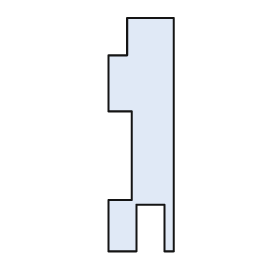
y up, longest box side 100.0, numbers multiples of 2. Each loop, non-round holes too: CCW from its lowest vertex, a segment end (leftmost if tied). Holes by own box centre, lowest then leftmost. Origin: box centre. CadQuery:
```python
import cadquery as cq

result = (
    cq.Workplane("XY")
    .moveTo(-14.0, -50.0)
    .lineTo(-2.0, -50.0)
    .lineTo(-2.0, -30.0)
    .lineTo(10.0, -30.0)
    .lineTo(10.0, -50.0)
    .lineTo(14.0, -50.0)
    .lineTo(14.0, 50.0)
    .lineTo(-6.0, 50.0)
    .lineTo(-6.0, 34.0)
    .lineTo(-14.0, 34.0)
    .lineTo(-14.0, 10.0)
    .lineTo(-4.0, 10.0)
    .lineTo(-4.0, -28.0)
    .lineTo(-14.0, -28.0)
    .close()
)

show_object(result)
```